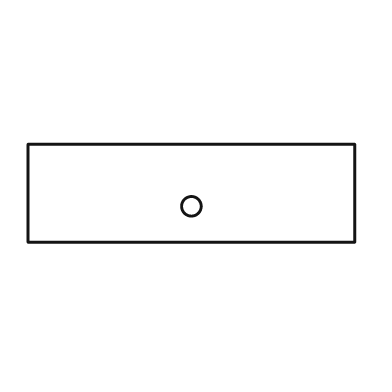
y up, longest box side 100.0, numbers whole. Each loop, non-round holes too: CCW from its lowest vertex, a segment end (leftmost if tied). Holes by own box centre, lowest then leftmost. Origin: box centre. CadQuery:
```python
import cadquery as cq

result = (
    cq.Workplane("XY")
    .moveTo(-50.0, -15.0)
    .lineTo(50.0, -15.0)
    .lineTo(50.0, 15.0)
    .lineTo(-50.0, 15.0)
    .close()
    .moveTo(0.0, -4.0)
    .circle(3.0)
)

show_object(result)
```